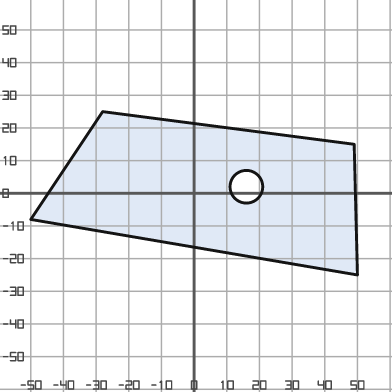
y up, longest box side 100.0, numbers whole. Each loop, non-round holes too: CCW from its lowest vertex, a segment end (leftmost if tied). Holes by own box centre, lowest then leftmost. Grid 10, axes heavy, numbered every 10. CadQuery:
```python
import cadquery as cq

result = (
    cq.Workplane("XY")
    .moveTo(50.0, -25.0)
    .lineTo(49.0, 15.0)
    .lineTo(-28.0, 25.0)
    .lineTo(-50.0, -8.0)
    .close()
    .moveTo(16.0, 2.0)
    .circle(5.0)
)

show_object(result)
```